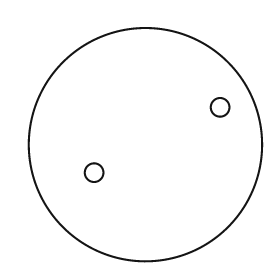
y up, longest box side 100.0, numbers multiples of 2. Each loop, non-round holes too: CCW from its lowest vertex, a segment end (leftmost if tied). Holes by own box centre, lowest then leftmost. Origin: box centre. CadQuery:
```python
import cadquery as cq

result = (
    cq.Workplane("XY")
    .moveTo(0.0, 0.0)
    .circle(50.0)
    .moveTo(-22.0, -12.0)
    .circle(4.0)
    .moveTo(32.0, 16.0)
    .circle(4.0)
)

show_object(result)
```